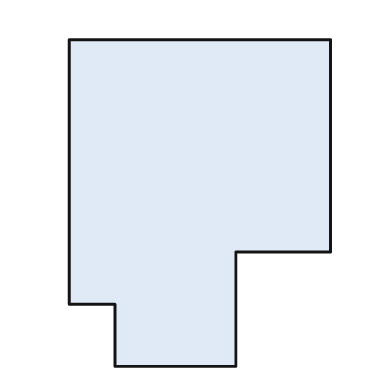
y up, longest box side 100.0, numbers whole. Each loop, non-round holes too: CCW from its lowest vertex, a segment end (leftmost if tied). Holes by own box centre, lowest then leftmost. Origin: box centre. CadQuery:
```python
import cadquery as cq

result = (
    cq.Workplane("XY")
    .moveTo(-26.0, -50.0)
    .lineTo(11.0, -50.0)
    .lineTo(11.0, -15.0)
    .lineTo(40.0, -15.0)
    .lineTo(40.0, 50.0)
    .lineTo(-40.0, 50.0)
    .lineTo(-40.0, -31.0)
    .lineTo(-26.0, -31.0)
    .close()
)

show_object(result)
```